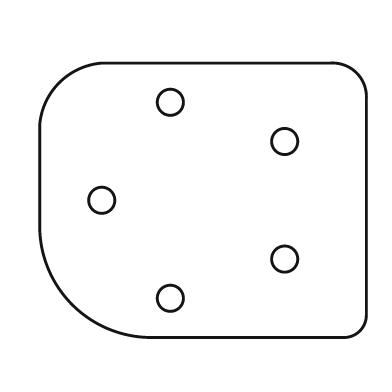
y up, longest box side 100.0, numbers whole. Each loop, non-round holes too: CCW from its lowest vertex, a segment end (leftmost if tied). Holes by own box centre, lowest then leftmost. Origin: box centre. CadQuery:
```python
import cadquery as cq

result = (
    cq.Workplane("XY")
    .moveTo(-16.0, -42.0)
    .lineTo(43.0, -42.0)
    .threePointArc((48.0, -40.0), (50.0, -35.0))
    .lineTo(50.0, 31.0)
    .threePointArc((47.0, 39.0), (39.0, 42.0))
    .lineTo(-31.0, 42.0)
    .threePointArc((-44.0, 36.0), (-50.0, 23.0))
    .lineTo(-50.0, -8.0)
    .threePointArc((-40.0, -32.0), (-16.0, -42.0))
    .close()
    .moveTo(-10.0, -30.0)
    .circle(4.0)
    .moveTo(25.0, -18.0)
    .circle(4.0)
    .moveTo(-31.0, 0.0)
    .circle(4.0)
    .moveTo(25.0, 18.0)
    .circle(4.0)
    .moveTo(-10.0, 30.0)
    .circle(4.0)
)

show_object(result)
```